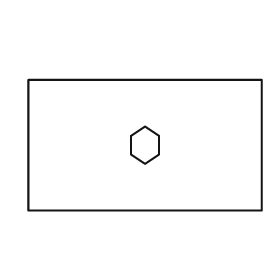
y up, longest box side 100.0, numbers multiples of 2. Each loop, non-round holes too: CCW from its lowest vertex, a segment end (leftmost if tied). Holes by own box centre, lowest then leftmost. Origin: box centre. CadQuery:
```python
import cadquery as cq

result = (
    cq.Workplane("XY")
    .moveTo(-50.0, -28.0)
    .lineTo(50.0, -28.0)
    .lineTo(50.0, 28.0)
    .lineTo(-50.0, 28.0)
    .close()
    .moveTo(0.0, -8.0)
    .lineTo(6.0, -4.0)
    .lineTo(6.0, 4.0)
    .lineTo(0.0, 8.0)
    .lineTo(-6.0, 4.0)
    .lineTo(-6.0, -4.0)
    .close()
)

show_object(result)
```